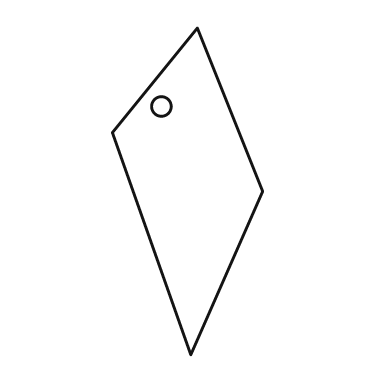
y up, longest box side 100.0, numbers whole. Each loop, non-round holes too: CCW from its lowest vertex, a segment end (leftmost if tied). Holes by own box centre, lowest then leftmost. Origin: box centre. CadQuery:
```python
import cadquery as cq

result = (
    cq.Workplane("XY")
    .moveTo(1.0, -50.0)
    .lineTo(23.0, 0.0)
    .lineTo(3.0, 50.0)
    .lineTo(-23.0, 18.0)
    .close()
    .moveTo(-8.0, 26.0)
    .circle(3.0)
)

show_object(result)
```